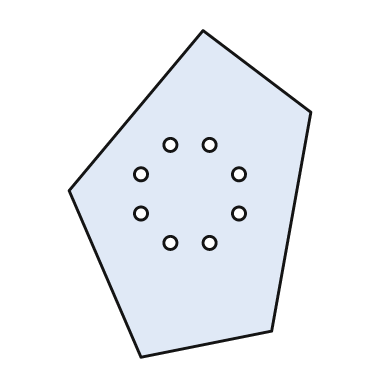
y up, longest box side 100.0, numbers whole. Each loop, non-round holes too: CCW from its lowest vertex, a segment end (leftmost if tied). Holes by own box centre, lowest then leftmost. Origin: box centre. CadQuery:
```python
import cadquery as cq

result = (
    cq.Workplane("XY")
    .moveTo(-15.0, -50.0)
    .lineTo(25.0, -42.0)
    .lineTo(37.0, 25.0)
    .lineTo(4.0, 50.0)
    .lineTo(-37.0, 1.0)
    .close()
    .moveTo(-6.0, -15.0)
    .circle(2.0)
    .moveTo(6.0, -15.0)
    .circle(2.0)
    .moveTo(-15.0, -6.0)
    .circle(2.0)
    .moveTo(15.0, -6.0)
    .circle(2.0)
    .moveTo(-15.0, 6.0)
    .circle(2.0)
    .moveTo(15.0, 6.0)
    .circle(2.0)
    .moveTo(-6.0, 15.0)
    .circle(2.0)
    .moveTo(6.0, 15.0)
    .circle(2.0)
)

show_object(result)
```